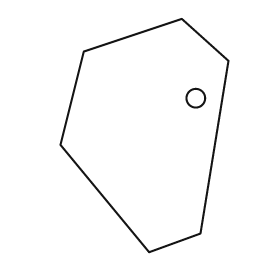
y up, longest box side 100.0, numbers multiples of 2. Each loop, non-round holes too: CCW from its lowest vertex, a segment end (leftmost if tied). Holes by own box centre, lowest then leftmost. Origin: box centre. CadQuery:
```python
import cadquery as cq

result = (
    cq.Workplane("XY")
    .moveTo(2.0, -50.0)
    .lineTo(24.0, -42.0)
    .lineTo(36.0, 32.0)
    .lineTo(16.0, 50.0)
    .lineTo(-26.0, 36.0)
    .lineTo(-36.0, -4.0)
    .close()
    .moveTo(22.0, 16.0)
    .circle(4.0)
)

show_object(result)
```